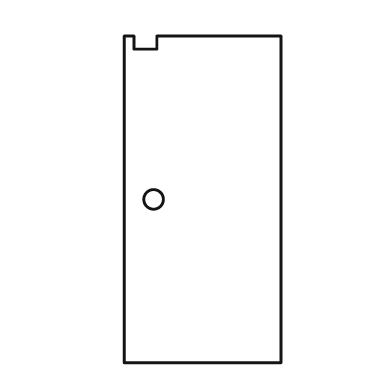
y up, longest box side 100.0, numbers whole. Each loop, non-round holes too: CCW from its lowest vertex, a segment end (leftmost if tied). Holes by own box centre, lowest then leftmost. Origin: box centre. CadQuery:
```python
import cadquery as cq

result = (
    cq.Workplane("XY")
    .moveTo(-24.0, -50.0)
    .lineTo(24.0, -50.0)
    .lineTo(24.0, 50.0)
    .lineTo(-14.0, 50.0)
    .lineTo(-14.0, 46.0)
    .lineTo(-21.0, 46.0)
    .lineTo(-21.0, 50.0)
    .lineTo(-24.0, 50.0)
    .close()
    .moveTo(-15.0, 0.0)
    .circle(3.0)
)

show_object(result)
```